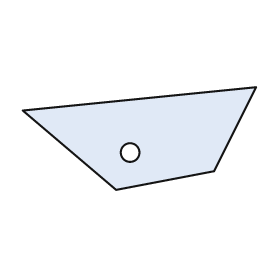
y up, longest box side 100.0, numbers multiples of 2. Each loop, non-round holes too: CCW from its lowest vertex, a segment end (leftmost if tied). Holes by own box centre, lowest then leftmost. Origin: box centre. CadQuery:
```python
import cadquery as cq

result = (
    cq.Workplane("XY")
    .moveTo(-10.0, -22.0)
    .lineTo(32.0, -14.0)
    .lineTo(50.0, 22.0)
    .lineTo(-50.0, 12.0)
    .close()
    .moveTo(-4.0, -6.0)
    .circle(4.0)
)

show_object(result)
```